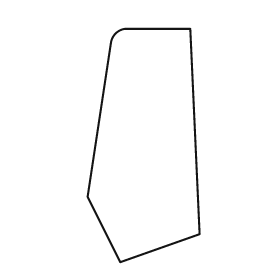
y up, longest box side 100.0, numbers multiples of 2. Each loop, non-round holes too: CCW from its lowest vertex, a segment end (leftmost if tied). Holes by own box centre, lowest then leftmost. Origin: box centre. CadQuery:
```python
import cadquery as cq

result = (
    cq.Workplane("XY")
    .moveTo(-10.0, -50.0)
    .lineTo(24.0, -38.0)
    .lineTo(20.0, 50.0)
    .lineTo(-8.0, 50.0)
    .threePointArc((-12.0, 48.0), (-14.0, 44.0))
    .lineTo(-24.0, -22.0)
    .close()
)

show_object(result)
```